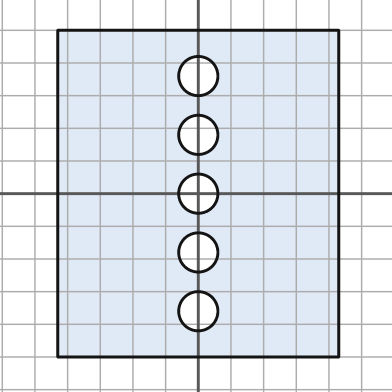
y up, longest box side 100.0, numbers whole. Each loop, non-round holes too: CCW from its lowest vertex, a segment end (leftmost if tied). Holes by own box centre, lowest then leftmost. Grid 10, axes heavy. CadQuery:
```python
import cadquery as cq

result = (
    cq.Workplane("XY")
    .moveTo(-43.0, -50.0)
    .lineTo(43.0, -50.0)
    .lineTo(43.0, 50.0)
    .lineTo(-43.0, 50.0)
    .close()
    .moveTo(0.0, -36.0)
    .circle(6.0)
    .moveTo(0.0, -18.0)
    .circle(6.0)
    .moveTo(0.0, 0.0)
    .circle(6.0)
    .moveTo(0.0, 18.0)
    .circle(6.0)
    .moveTo(0.0, 36.0)
    .circle(6.0)
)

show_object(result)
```